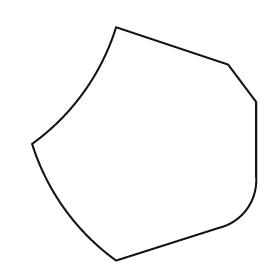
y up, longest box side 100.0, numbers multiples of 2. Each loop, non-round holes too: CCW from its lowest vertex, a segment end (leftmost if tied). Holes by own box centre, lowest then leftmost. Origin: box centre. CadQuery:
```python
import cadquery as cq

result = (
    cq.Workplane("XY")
    .moveTo(-12.0, -50.0)
    .lineTo(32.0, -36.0)
    .threePointArc((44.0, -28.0), (48.0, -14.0))
    .lineTo(48.0, 18.0)
    .lineTo(36.0, 34.0)
    .lineTo(-12.0, 50.0)
    .threePointArc((-26.0, 22.0), (-48.0, 0.0))
    .threePointArc((-34.0, -28.0), (-12.0, -50.0))
    .close()
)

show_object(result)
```